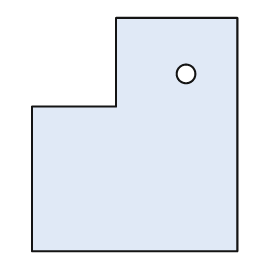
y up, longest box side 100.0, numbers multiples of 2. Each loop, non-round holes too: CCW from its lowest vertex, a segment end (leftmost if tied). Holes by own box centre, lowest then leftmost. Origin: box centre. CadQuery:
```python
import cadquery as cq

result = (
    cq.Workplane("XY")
    .moveTo(-44.0, -50.0)
    .lineTo(44.0, -50.0)
    .lineTo(44.0, 50.0)
    .lineTo(-8.0, 50.0)
    .lineTo(-8.0, 12.0)
    .lineTo(-44.0, 12.0)
    .close()
    .moveTo(22.0, 26.0)
    .circle(4.0)
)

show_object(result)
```